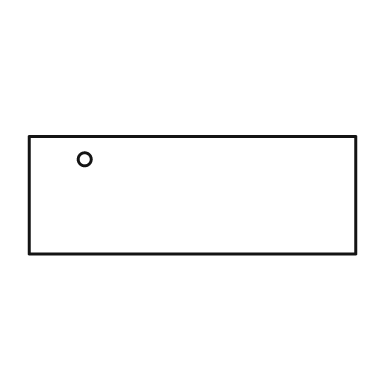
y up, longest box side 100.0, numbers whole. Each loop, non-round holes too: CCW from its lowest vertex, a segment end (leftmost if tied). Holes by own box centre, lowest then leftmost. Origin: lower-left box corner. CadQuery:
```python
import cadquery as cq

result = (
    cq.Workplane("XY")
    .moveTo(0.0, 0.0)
    .lineTo(100.0, 0.0)
    .lineTo(100.0, 36.0)
    .lineTo(0.0, 36.0)
    .close()
    .moveTo(17.0, 29.0)
    .circle(2.0)
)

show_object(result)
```